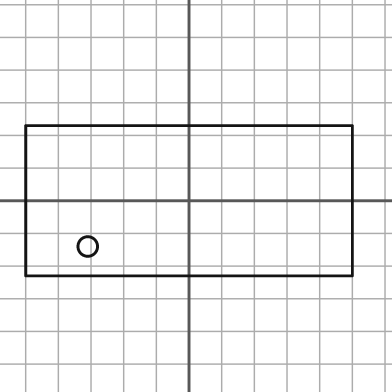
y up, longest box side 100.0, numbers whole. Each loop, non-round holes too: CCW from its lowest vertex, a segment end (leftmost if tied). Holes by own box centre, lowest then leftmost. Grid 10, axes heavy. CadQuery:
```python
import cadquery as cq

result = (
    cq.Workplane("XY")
    .moveTo(-50.0, -23.0)
    .lineTo(50.0, -23.0)
    .lineTo(50.0, 23.0)
    .lineTo(-50.0, 23.0)
    .close()
    .moveTo(-31.0, -14.0)
    .circle(3.0)
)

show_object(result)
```